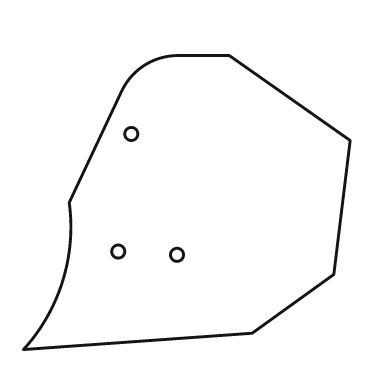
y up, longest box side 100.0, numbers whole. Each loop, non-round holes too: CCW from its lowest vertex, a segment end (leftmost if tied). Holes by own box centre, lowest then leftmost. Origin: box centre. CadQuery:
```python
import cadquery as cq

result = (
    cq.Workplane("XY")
    .moveTo(-50.0, -45.0)
    .lineTo(20.0, -40.0)
    .lineTo(45.0, -22.0)
    .lineTo(50.0, 19.0)
    .lineTo(13.0, 45.0)
    .lineTo(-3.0, 45.0)
    .threePointArc((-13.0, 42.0), (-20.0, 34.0))
    .lineTo(-36.0, 0.0)
    .threePointArc((-38.0, -24.0), (-50.0, -45.0))
    .close()
    .moveTo(-3.0, -16.0)
    .circle(2.0)
    .moveTo(-21.0, -15.0)
    .circle(2.0)
    .moveTo(-17.0, 21.0)
    .circle(2.0)
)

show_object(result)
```